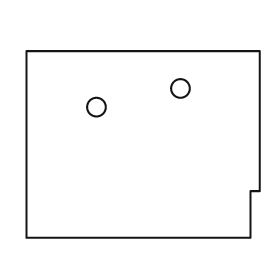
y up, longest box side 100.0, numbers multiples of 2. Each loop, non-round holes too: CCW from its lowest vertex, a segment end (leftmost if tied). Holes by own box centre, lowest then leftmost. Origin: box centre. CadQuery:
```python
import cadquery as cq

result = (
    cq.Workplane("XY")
    .moveTo(-50.0, -40.0)
    .lineTo(46.0, -40.0)
    .lineTo(46.0, -20.0)
    .lineTo(50.0, -20.0)
    .lineTo(50.0, 40.0)
    .lineTo(-50.0, 40.0)
    .close()
    .moveTo(-20.0, 16.0)
    .circle(4.0)
    .moveTo(16.0, 24.0)
    .circle(4.0)
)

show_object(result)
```